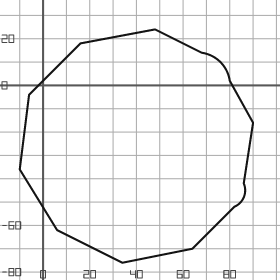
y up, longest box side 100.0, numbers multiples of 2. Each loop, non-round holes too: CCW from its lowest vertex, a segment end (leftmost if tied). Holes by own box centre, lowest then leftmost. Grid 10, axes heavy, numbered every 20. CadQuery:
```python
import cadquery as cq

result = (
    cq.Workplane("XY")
    .moveTo(34.0, -76.0)
    .lineTo(64.0, -70.0)
    .lineTo(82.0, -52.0)
    .threePointArc((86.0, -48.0), (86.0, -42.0))
    .lineTo(90.0, -16.0)
    .lineTo(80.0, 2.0)
    .threePointArc((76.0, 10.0), (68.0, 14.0))
    .lineTo(48.0, 24.0)
    .lineTo(16.0, 18.0)
    .lineTo(-6.0, -4.0)
    .lineTo(-10.0, -36.0)
    .lineTo(6.0, -62.0)
    .close()
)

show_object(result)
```